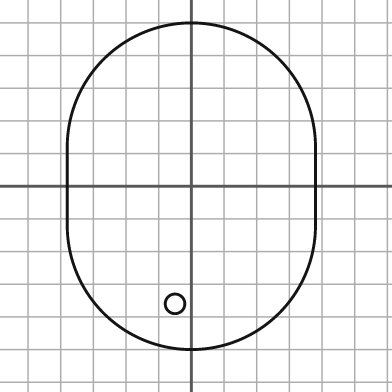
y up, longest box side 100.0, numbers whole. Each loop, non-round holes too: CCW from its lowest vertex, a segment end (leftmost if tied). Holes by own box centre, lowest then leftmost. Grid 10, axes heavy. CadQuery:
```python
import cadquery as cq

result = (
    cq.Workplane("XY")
    .moveTo(-38.0, -12.0)
    .threePointArc((0.0, -50.0), (38.0, -12.0))
    .lineTo(38.0, 12.0)
    .threePointArc((0.0, 50.0), (-38.0, 12.0))
    .close()
    .moveTo(-5.0, -36.0)
    .circle(3.0)
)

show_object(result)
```